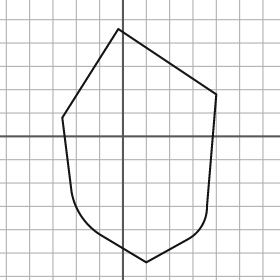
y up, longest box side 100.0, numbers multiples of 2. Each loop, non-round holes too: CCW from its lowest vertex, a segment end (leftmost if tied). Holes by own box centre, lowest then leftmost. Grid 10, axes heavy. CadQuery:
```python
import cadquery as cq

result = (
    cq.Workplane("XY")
    .moveTo(10.0, -54.0)
    .lineTo(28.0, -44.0)
    .threePointArc((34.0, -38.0), (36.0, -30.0))
    .lineTo(40.0, 18.0)
    .lineTo(-2.0, 46.0)
    .lineTo(-26.0, 8.0)
    .lineTo(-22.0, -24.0)
    .threePointArc((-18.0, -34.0), (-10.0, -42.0))
    .close()
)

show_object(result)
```